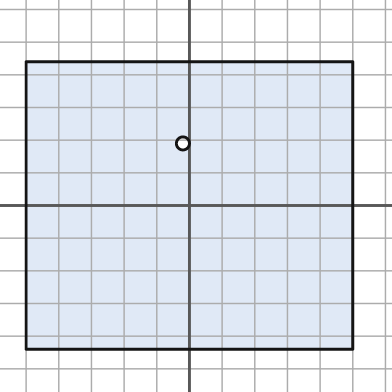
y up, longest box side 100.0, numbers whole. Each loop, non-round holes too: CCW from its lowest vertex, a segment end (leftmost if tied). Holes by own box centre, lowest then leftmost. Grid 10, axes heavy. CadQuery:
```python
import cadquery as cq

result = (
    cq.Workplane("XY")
    .moveTo(-50.0, -44.0)
    .lineTo(50.0, -44.0)
    .lineTo(50.0, 44.0)
    .lineTo(-50.0, 44.0)
    .close()
    .moveTo(-2.0, 19.0)
    .circle(2.0)
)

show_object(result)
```